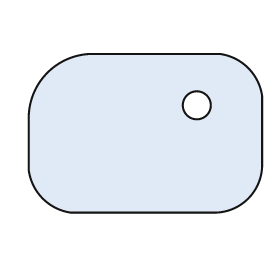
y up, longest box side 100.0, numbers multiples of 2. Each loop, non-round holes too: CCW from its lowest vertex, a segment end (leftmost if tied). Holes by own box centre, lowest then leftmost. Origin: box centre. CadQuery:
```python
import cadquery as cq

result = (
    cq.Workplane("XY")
    .moveTo(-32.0, -34.0)
    .lineTo(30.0, -34.0)
    .threePointArc((44.0, -28.0), (50.0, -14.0))
    .lineTo(50.0, 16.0)
    .threePointArc((44.0, 28.0), (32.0, 34.0))
    .lineTo(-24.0, 34.0)
    .threePointArc((-42.0, 26.0), (-50.0, 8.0))
    .lineTo(-50.0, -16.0)
    .threePointArc((-44.0, -28.0), (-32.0, -34.0))
    .close()
    .moveTo(22.0, 12.0)
    .circle(6.0)
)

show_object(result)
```